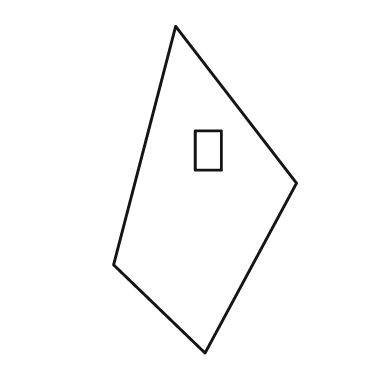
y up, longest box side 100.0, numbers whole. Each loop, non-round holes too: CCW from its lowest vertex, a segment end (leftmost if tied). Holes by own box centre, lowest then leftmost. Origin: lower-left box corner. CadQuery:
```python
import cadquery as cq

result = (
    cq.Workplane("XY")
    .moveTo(28.0, 0.0)
    .lineTo(56.0, 52.0)
    .lineTo(19.0, 100.0)
    .lineTo(0.0, 27.0)
    .close()
    .moveTo(25.0, 56.0)
    .lineTo(33.0, 56.0)
    .lineTo(33.0, 68.0)
    .lineTo(25.0, 68.0)
    .close()
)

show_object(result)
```